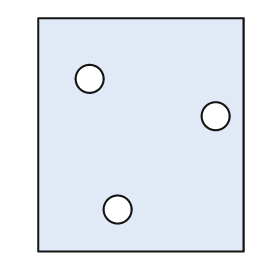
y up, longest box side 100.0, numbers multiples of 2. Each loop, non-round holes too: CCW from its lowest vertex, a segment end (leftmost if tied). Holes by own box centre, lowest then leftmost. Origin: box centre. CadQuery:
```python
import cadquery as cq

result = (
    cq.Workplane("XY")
    .moveTo(-44.0, -50.0)
    .lineTo(44.0, -50.0)
    .lineTo(44.0, 50.0)
    .lineTo(-44.0, 50.0)
    .close()
    .moveTo(-10.0, -32.0)
    .circle(6.0)
    .moveTo(32.0, 8.0)
    .circle(6.0)
    .moveTo(-22.0, 24.0)
    .circle(6.0)
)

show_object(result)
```